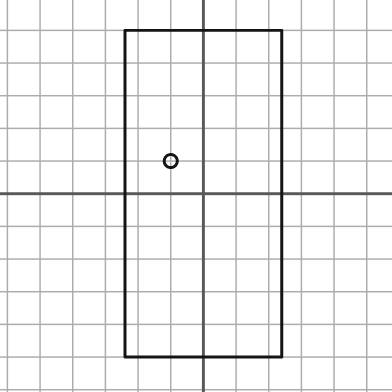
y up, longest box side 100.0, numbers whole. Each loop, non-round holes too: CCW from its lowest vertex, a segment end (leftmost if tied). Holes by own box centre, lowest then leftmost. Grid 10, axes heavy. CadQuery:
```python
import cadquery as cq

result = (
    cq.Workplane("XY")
    .moveTo(-24.0, -50.0)
    .lineTo(24.0, -50.0)
    .lineTo(24.0, 50.0)
    .lineTo(-24.0, 50.0)
    .close()
    .moveTo(-10.0, 10.0)
    .circle(2.0)
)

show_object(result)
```